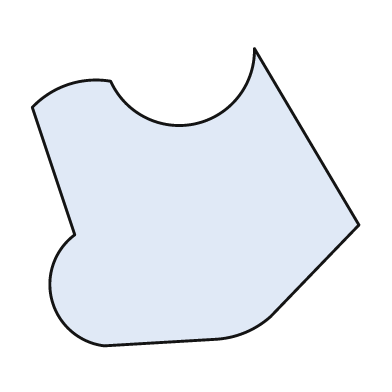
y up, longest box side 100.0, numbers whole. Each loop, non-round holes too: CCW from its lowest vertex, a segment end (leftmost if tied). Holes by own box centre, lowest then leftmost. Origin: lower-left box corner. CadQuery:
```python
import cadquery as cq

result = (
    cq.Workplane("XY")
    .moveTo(22.0, 0.0)
    .lineTo(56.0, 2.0)
    .threePointArc((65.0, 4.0), (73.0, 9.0))
    .lineTo(100.0, 37.0)
    .lineTo(68.0, 91.0)
    .threePointArc((50.0, 68.0), (24.0, 81.0))
    .threePointArc((11.0, 80.0), (0.0, 73.0))
    .lineTo(13.0, 34.0)
    .threePointArc((6.0, 14.0), (22.0, 0.0))
    .close()
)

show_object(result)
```